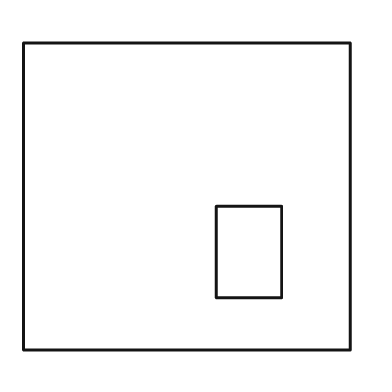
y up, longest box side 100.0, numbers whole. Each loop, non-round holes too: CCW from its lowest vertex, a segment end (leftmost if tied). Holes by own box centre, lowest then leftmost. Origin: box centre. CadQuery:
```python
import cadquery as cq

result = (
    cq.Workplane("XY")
    .moveTo(-50.0, -47.0)
    .lineTo(50.0, -47.0)
    .lineTo(50.0, 47.0)
    .lineTo(-50.0, 47.0)
    .close()
    .moveTo(9.0, -31.0)
    .lineTo(29.0, -31.0)
    .lineTo(29.0, -3.0)
    .lineTo(9.0, -3.0)
    .close()
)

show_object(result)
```